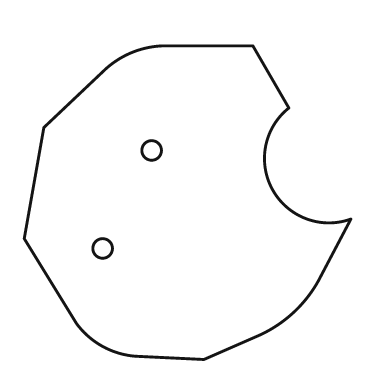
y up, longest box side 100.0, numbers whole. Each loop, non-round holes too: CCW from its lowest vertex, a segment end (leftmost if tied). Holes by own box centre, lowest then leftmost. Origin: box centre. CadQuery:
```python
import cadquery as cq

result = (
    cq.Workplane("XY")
    .moveTo(5.0, -48.0)
    .lineTo(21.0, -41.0)
    .threePointArc((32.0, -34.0), (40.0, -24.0))
    .lineTo(50.0, -5.0)
    .threePointArc((26.0, 4.0), (31.0, 29.0))
    .lineTo(20.0, 48.0)
    .lineTo(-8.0, 48.0)
    .threePointArc((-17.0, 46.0), (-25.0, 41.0))
    .lineTo(-44.0, 23.0)
    .lineTo(-50.0, -11.0)
    .lineTo(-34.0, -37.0)
    .threePointArc((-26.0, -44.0), (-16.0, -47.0))
    .close()
    .moveTo(-26.0, -14.0)
    .circle(3.0)
    .moveTo(-11.0, 16.0)
    .circle(3.0)
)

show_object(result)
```